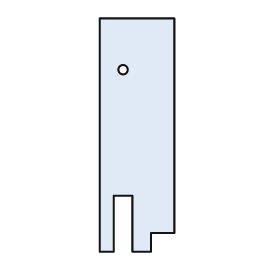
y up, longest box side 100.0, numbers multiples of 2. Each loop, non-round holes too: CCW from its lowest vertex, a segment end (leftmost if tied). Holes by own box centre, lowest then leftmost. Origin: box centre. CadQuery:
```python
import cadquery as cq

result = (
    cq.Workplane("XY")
    .moveTo(-16.0, -50.0)
    .lineTo(-10.0, -50.0)
    .lineTo(-10.0, -26.0)
    .lineTo(-2.0, -26.0)
    .lineTo(-2.0, -50.0)
    .lineTo(6.0, -50.0)
    .lineTo(6.0, -42.0)
    .lineTo(16.0, -42.0)
    .lineTo(16.0, 50.0)
    .lineTo(-16.0, 50.0)
    .close()
    .moveTo(-6.0, 28.0)
    .circle(2.0)
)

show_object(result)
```